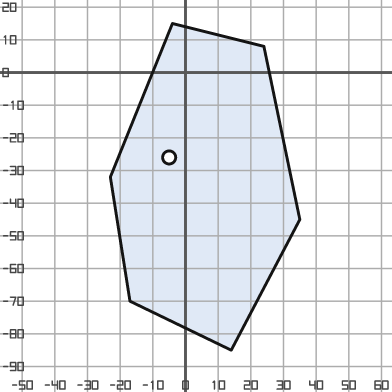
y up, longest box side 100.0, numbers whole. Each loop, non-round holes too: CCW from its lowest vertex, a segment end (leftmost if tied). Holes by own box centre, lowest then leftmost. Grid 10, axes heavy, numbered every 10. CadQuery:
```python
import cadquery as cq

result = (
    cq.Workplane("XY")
    .moveTo(14.0, -85.0)
    .lineTo(35.0, -45.0)
    .lineTo(24.0, 8.0)
    .lineTo(-4.0, 15.0)
    .lineTo(-23.0, -32.0)
    .lineTo(-17.0, -70.0)
    .close()
    .moveTo(-5.0, -26.0)
    .circle(2.0)
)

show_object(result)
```